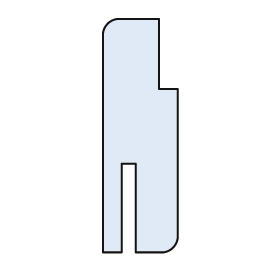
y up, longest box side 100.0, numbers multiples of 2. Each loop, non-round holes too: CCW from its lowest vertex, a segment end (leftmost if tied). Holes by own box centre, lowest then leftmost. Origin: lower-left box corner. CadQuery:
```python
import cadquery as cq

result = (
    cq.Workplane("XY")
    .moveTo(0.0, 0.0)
    .lineTo(8.0, 0.0)
    .lineTo(8.0, 38.0)
    .lineTo(14.0, 38.0)
    .lineTo(14.0, 0.0)
    .lineTo(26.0, 0.0)
    .threePointArc((30.0, 2.0), (32.0, 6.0))
    .lineTo(32.0, 70.0)
    .lineTo(24.0, 70.0)
    .lineTo(24.0, 100.0)
    .lineTo(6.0, 100.0)
    .threePointArc((2.0, 98.0), (0.0, 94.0))
    .close()
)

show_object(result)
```